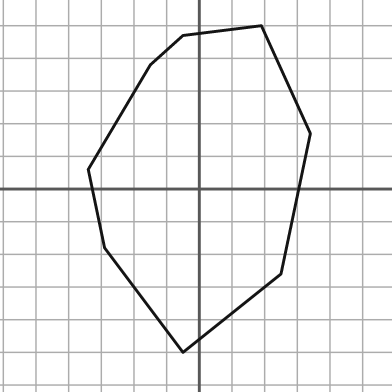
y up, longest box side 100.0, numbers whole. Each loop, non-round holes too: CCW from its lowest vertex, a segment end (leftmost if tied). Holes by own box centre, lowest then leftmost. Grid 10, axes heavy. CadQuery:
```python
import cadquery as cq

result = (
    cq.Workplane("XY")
    .moveTo(-5.0, -50.0)
    .lineTo(25.0, -26.0)
    .lineTo(34.0, 17.0)
    .lineTo(19.0, 50.0)
    .lineTo(-5.0, 47.0)
    .lineTo(-15.0, 38.0)
    .lineTo(-34.0, 6.0)
    .lineTo(-29.0, -18.0)
    .close()
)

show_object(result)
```